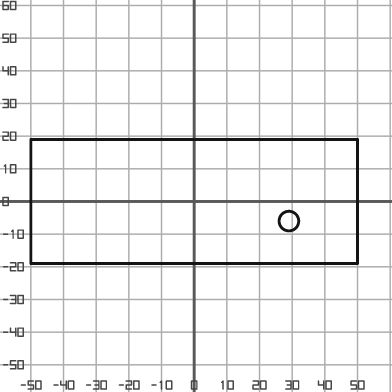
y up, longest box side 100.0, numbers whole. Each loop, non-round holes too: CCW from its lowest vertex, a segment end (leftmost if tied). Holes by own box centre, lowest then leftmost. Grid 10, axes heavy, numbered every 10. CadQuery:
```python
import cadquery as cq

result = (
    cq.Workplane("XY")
    .moveTo(-50.0, -19.0)
    .lineTo(50.0, -19.0)
    .lineTo(50.0, 19.0)
    .lineTo(-50.0, 19.0)
    .close()
    .moveTo(29.0, -6.0)
    .circle(3.0)
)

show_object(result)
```